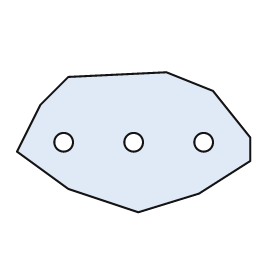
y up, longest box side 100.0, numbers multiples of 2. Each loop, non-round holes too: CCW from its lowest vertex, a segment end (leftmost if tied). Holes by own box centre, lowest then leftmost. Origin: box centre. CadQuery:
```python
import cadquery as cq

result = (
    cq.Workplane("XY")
    .moveTo(2.0, -30.0)
    .lineTo(28.0, -22.0)
    .lineTo(50.0, -8.0)
    .lineTo(50.0, 2.0)
    .lineTo(34.0, 22.0)
    .lineTo(14.0, 30.0)
    .lineTo(-28.0, 28.0)
    .lineTo(-40.0, 16.0)
    .lineTo(-50.0, -4.0)
    .lineTo(-28.0, -20.0)
    .close()
    .moveTo(-30.0, 0.0)
    .circle(4.0)
    .moveTo(0.0, 0.0)
    .circle(4.0)
    .moveTo(30.0, 0.0)
    .circle(4.0)
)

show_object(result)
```